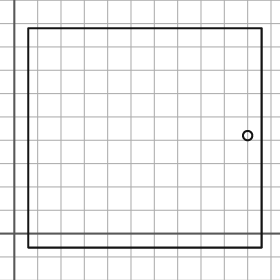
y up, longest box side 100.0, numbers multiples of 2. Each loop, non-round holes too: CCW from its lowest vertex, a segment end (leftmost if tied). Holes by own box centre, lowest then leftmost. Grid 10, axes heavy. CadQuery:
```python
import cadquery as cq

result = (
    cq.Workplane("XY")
    .moveTo(6.0, -6.0)
    .lineTo(106.0, -6.0)
    .lineTo(106.0, 88.0)
    .lineTo(6.0, 88.0)
    .close()
    .moveTo(100.0, 42.0)
    .circle(2.0)
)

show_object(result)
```